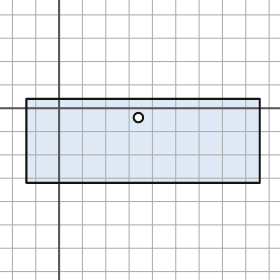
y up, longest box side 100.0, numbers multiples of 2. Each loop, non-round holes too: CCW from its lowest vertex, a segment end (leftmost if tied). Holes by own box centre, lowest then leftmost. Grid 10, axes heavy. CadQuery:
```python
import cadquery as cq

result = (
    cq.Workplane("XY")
    .moveTo(-14.0, -32.0)
    .lineTo(86.0, -32.0)
    .lineTo(86.0, 4.0)
    .lineTo(-14.0, 4.0)
    .close()
    .moveTo(34.0, -4.0)
    .circle(2.0)
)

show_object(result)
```